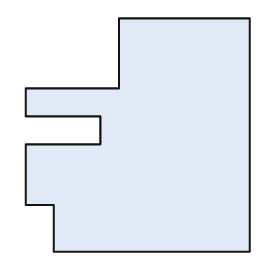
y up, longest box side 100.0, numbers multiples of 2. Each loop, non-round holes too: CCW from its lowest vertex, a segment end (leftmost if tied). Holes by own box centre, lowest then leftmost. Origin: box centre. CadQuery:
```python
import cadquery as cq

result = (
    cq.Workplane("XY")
    .moveTo(-36.0, -50.0)
    .lineTo(48.0, -50.0)
    .lineTo(48.0, 50.0)
    .lineTo(-8.0, 50.0)
    .lineTo(-8.0, 20.0)
    .lineTo(-48.0, 20.0)
    .lineTo(-48.0, 8.0)
    .lineTo(-16.0, 8.0)
    .lineTo(-16.0, -4.0)
    .lineTo(-48.0, -4.0)
    .lineTo(-48.0, -30.0)
    .lineTo(-36.0, -30.0)
    .close()
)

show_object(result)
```